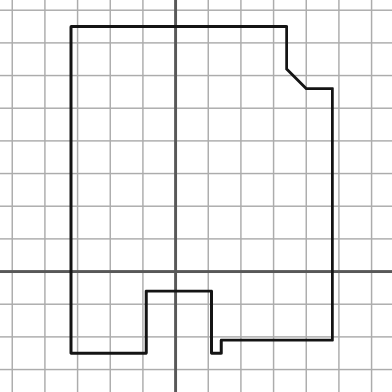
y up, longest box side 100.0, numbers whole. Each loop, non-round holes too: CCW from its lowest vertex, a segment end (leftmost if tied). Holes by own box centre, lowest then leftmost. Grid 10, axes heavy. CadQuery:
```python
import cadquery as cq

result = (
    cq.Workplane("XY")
    .moveTo(-32.0, -25.0)
    .lineTo(-9.0, -25.0)
    .lineTo(-9.0, -6.0)
    .lineTo(11.0, -6.0)
    .lineTo(11.0, -25.0)
    .lineTo(14.0, -25.0)
    .lineTo(14.0, -21.0)
    .lineTo(48.0, -21.0)
    .lineTo(48.0, 56.0)
    .lineTo(40.0, 56.0)
    .lineTo(34.0, 62.0)
    .lineTo(34.0, 75.0)
    .lineTo(-32.0, 75.0)
    .close()
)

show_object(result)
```